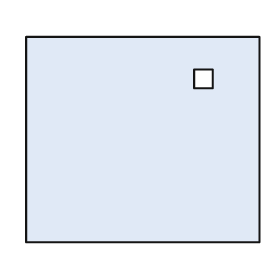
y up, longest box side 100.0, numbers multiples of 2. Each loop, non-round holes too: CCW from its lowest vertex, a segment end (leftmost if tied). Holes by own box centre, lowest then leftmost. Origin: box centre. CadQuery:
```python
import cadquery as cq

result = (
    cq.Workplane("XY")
    .moveTo(-50.0, -44.0)
    .lineTo(50.0, -44.0)
    .lineTo(50.0, 44.0)
    .lineTo(-50.0, 44.0)
    .close()
    .moveTo(22.0, 22.0)
    .lineTo(30.0, 22.0)
    .lineTo(30.0, 30.0)
    .lineTo(22.0, 30.0)
    .close()
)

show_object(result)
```